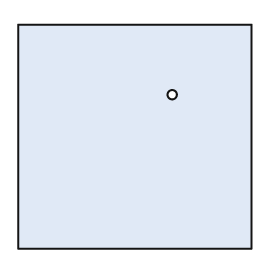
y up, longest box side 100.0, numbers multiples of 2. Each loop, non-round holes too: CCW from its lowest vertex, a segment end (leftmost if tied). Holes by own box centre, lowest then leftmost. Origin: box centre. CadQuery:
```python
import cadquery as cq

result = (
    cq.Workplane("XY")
    .moveTo(-50.0, -48.0)
    .lineTo(50.0, -48.0)
    .lineTo(50.0, 48.0)
    .lineTo(-50.0, 48.0)
    .close()
    .moveTo(16.0, 18.0)
    .circle(2.0)
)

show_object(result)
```